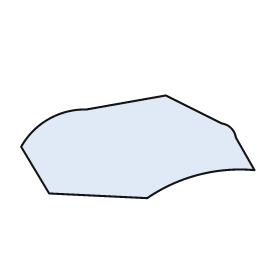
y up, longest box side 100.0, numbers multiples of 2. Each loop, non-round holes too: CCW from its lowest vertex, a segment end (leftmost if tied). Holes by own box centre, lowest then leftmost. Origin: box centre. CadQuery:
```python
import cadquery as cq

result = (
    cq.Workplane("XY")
    .moveTo(4.0, -22.0)
    .threePointArc((26.0, -12.0), (50.0, -10.0))
    .lineTo(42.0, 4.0)
    .threePointArc((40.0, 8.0), (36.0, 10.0))
    .lineTo(12.0, 22.0)
    .lineTo(-22.0, 16.0)
    .threePointArc((-38.0, 12.0), (-50.0, 0.0))
    .lineTo(-38.0, -20.0)
    .close()
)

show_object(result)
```